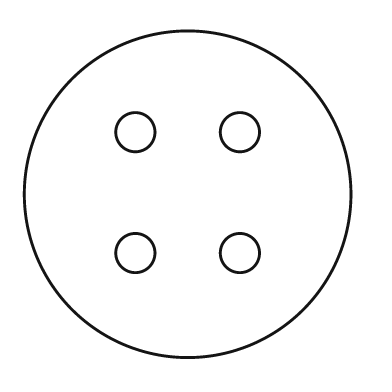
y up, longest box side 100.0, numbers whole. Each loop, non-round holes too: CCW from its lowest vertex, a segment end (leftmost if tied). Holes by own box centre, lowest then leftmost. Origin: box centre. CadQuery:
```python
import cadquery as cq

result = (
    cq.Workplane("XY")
    .moveTo(0.0, 0.0)
    .circle(50.0)
    .moveTo(-16.0, -18.0)
    .circle(6.0)
    .moveTo(16.0, -18.0)
    .circle(6.0)
    .moveTo(-16.0, 19.0)
    .circle(6.0)
    .moveTo(16.0, 19.0)
    .circle(6.0)
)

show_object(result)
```